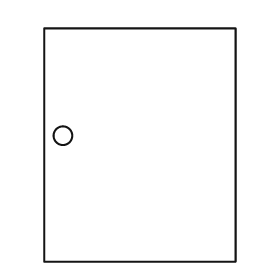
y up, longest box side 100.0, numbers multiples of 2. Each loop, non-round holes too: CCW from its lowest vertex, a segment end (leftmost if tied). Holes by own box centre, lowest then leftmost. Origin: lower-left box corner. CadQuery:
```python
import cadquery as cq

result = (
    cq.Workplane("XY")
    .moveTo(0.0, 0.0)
    .lineTo(82.0, 0.0)
    .lineTo(82.0, 100.0)
    .lineTo(0.0, 100.0)
    .close()
    .moveTo(8.0, 54.0)
    .circle(4.0)
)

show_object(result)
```